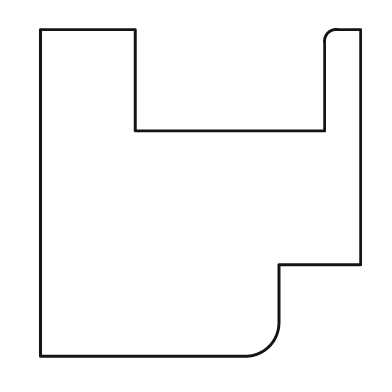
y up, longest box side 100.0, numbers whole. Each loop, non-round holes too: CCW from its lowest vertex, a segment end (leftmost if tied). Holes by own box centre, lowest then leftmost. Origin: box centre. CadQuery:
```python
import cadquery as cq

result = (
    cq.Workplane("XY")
    .moveTo(-49.0, -50.0)
    .lineTo(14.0, -50.0)
    .threePointArc((21.0, -47.0), (24.0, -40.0))
    .lineTo(24.0, -22.0)
    .lineTo(49.0, -22.0)
    .lineTo(49.0, 50.0)
    .lineTo(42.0, 50.0)
    .threePointArc((39.0, 49.0), (38.0, 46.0))
    .lineTo(38.0, 19.0)
    .lineTo(-20.0, 19.0)
    .lineTo(-20.0, 50.0)
    .lineTo(-49.0, 50.0)
    .close()
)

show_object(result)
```